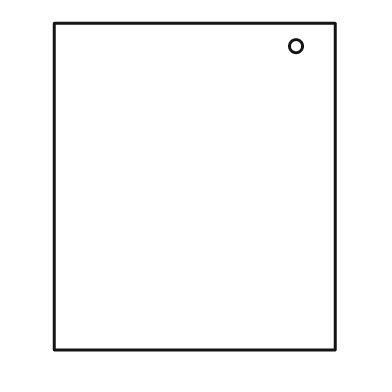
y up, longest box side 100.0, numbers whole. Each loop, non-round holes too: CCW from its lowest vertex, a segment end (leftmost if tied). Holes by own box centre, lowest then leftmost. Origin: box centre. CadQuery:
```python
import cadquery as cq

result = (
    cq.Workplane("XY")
    .moveTo(-43.0, -50.0)
    .lineTo(43.0, -50.0)
    .lineTo(43.0, 50.0)
    .lineTo(-43.0, 50.0)
    .close()
    .moveTo(31.0, 43.0)
    .circle(2.0)
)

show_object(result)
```